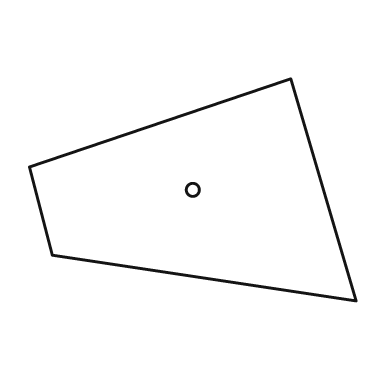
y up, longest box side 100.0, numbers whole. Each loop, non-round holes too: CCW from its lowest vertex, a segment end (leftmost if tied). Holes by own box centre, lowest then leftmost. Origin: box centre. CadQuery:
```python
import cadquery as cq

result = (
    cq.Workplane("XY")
    .moveTo(50.0, -34.0)
    .lineTo(30.0, 34.0)
    .lineTo(-50.0, 7.0)
    .lineTo(-43.0, -20.0)
    .close()
    .moveTo(0.0, 0.0)
    .circle(2.0)
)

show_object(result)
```